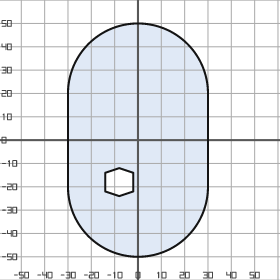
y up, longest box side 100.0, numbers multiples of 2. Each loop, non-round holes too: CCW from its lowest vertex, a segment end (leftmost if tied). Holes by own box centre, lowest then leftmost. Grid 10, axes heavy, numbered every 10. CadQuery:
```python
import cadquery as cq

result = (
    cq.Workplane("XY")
    .moveTo(-30.0, -20.0)
    .threePointArc((0.0, -50.0), (30.0, -20.0))
    .lineTo(30.0, 20.0)
    .threePointArc((0.0, 50.0), (-30.0, 20.0))
    .close()
    .moveTo(-8.0, -24.0)
    .lineTo(-2.0, -22.0)
    .lineTo(-2.0, -14.0)
    .lineTo(-8.0, -12.0)
    .lineTo(-14.0, -14.0)
    .lineTo(-14.0, -22.0)
    .close()
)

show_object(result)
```